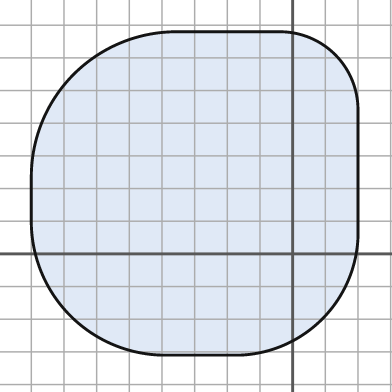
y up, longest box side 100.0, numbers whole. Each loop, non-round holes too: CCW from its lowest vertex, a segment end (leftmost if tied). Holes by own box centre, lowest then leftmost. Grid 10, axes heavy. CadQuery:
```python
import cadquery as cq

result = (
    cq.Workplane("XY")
    .moveTo(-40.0, -31.0)
    .lineTo(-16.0, -31.0)
    .threePointArc((9.0, -20.0), (20.0, 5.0))
    .lineTo(20.0, 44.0)
    .threePointArc((13.0, 61.0), (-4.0, 68.0))
    .lineTo(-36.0, 68.0)
    .threePointArc((-67.0, 55.0), (-80.0, 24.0))
    .lineTo(-80.0, 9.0)
    .threePointArc((-68.0, -19.0), (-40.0, -31.0))
    .close()
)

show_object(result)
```